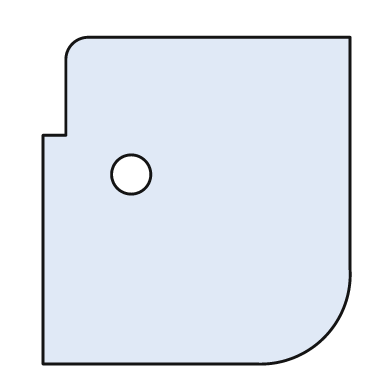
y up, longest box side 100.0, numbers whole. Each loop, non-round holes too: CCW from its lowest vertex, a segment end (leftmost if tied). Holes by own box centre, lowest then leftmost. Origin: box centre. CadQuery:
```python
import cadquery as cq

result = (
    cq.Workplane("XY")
    .moveTo(-47.0, -50.0)
    .lineTo(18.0, -50.0)
    .threePointArc((39.0, -42.0), (47.0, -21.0))
    .lineTo(47.0, 50.0)
    .lineTo(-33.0, 50.0)
    .threePointArc((-38.0, 48.0), (-40.0, 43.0))
    .lineTo(-40.0, 20.0)
    .lineTo(-47.0, 20.0)
    .close()
    .moveTo(-20.0, 8.0)
    .circle(6.0)
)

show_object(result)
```